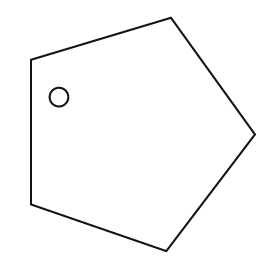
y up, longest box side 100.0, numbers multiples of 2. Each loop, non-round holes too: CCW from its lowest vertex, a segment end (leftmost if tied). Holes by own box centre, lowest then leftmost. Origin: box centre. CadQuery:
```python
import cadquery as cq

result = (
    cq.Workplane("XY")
    .moveTo(10.0, -50.0)
    .lineTo(48.0, 0.0)
    .lineTo(12.0, 50.0)
    .lineTo(-48.0, 32.0)
    .lineTo(-48.0, -30.0)
    .close()
    .moveTo(-36.0, 16.0)
    .circle(4.0)
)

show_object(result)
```